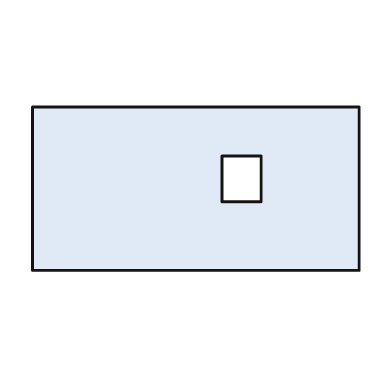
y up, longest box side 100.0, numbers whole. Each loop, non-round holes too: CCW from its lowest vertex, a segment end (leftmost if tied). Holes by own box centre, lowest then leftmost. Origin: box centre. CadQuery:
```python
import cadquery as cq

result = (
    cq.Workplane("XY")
    .moveTo(-50.0, -25.0)
    .lineTo(50.0, -25.0)
    .lineTo(50.0, 25.0)
    .lineTo(-50.0, 25.0)
    .close()
    .moveTo(8.0, -4.0)
    .lineTo(20.0, -4.0)
    .lineTo(20.0, 10.0)
    .lineTo(8.0, 10.0)
    .close()
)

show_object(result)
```